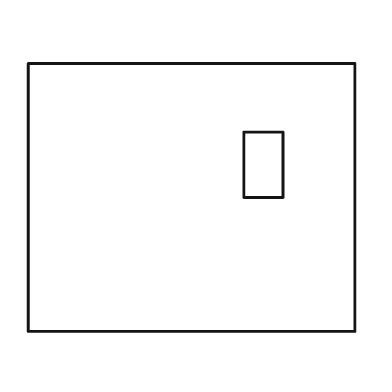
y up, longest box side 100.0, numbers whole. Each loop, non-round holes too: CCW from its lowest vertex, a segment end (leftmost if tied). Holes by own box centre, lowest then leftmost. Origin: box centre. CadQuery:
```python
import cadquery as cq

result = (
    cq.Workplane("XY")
    .moveTo(-50.0, -41.0)
    .lineTo(50.0, -41.0)
    .lineTo(50.0, 41.0)
    .lineTo(-50.0, 41.0)
    .close()
    .moveTo(16.0, 0.0)
    .lineTo(28.0, 0.0)
    .lineTo(28.0, 20.0)
    .lineTo(16.0, 20.0)
    .close()
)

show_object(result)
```